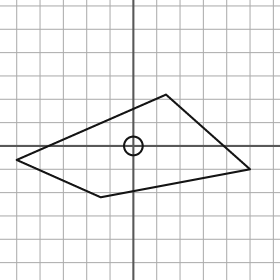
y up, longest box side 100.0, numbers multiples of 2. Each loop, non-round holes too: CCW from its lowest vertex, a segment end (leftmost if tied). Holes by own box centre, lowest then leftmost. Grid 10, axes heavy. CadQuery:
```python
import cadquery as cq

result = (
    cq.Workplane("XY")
    .moveTo(-14.0, -22.0)
    .lineTo(50.0, -10.0)
    .lineTo(14.0, 22.0)
    .lineTo(-50.0, -6.0)
    .close()
    .moveTo(0.0, 0.0)
    .circle(4.0)
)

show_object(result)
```